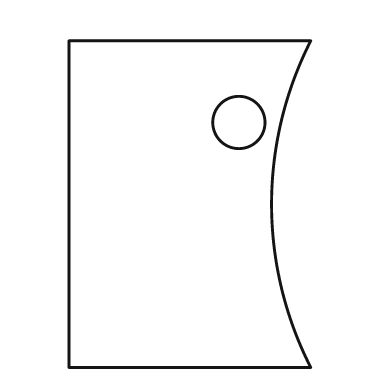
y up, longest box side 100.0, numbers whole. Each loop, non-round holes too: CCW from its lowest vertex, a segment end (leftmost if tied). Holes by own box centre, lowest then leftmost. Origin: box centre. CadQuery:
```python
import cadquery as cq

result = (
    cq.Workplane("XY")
    .moveTo(-37.0, -50.0)
    .lineTo(37.0, -50.0)
    .threePointArc((25.0, 0.0), (37.0, 50.0))
    .lineTo(-37.0, 50.0)
    .close()
    .moveTo(15.0, 25.0)
    .circle(8.0)
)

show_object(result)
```